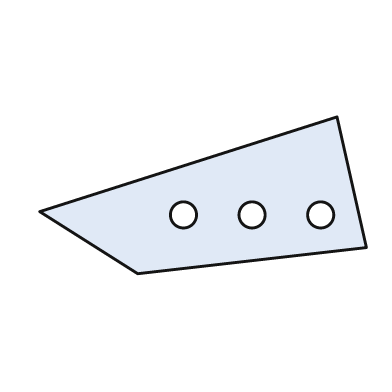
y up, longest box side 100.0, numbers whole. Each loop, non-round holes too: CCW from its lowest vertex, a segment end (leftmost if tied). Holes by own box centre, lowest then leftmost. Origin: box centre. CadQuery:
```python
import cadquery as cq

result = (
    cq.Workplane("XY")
    .moveTo(-20.0, -24.0)
    .lineTo(50.0, -16.0)
    .lineTo(41.0, 24.0)
    .lineTo(-50.0, -5.0)
    .close()
    .moveTo(-6.0, -6.0)
    .circle(4.0)
    .moveTo(15.0, -6.0)
    .circle(4.0)
    .moveTo(36.0, -6.0)
    .circle(4.0)
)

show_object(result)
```